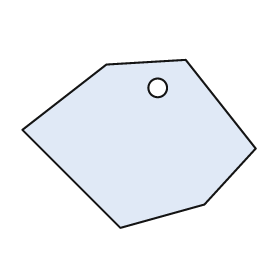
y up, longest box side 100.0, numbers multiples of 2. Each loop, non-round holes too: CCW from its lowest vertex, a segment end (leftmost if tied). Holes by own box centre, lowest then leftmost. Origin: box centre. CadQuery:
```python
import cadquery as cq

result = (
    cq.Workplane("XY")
    .moveTo(-8.0, -36.0)
    .lineTo(28.0, -26.0)
    .lineTo(50.0, -2.0)
    .lineTo(20.0, 36.0)
    .lineTo(-14.0, 34.0)
    .lineTo(-50.0, 6.0)
    .close()
    .moveTo(8.0, 24.0)
    .circle(4.0)
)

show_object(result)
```